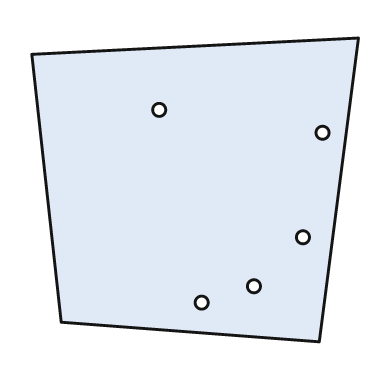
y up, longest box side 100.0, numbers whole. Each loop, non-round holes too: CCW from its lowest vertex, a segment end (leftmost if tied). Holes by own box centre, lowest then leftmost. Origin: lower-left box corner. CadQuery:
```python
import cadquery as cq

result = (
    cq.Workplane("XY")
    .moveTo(88.0, 0.0)
    .lineTo(100.0, 93.0)
    .lineTo(0.0, 88.0)
    .lineTo(9.0, 6.0)
    .close()
    .moveTo(52.0, 12.0)
    .circle(2.0)
    .moveTo(68.0, 17.0)
    .circle(2.0)
    .moveTo(83.0, 32.0)
    .circle(2.0)
    .moveTo(89.0, 64.0)
    .circle(2.0)
    .moveTo(39.0, 71.0)
    .circle(2.0)
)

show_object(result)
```